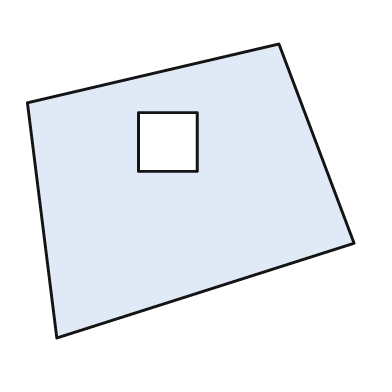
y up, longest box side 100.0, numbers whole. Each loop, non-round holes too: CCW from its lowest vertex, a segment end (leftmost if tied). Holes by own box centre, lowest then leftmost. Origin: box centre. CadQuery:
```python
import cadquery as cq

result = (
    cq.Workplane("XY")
    .moveTo(-41.0, -45.0)
    .lineTo(50.0, -16.0)
    .lineTo(27.0, 45.0)
    .lineTo(-50.0, 27.0)
    .close()
    .moveTo(-16.0, 6.0)
    .lineTo(2.0, 6.0)
    .lineTo(2.0, 24.0)
    .lineTo(-16.0, 24.0)
    .close()
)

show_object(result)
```